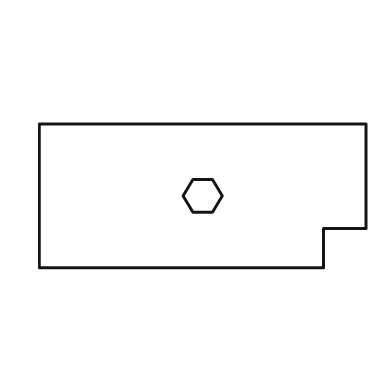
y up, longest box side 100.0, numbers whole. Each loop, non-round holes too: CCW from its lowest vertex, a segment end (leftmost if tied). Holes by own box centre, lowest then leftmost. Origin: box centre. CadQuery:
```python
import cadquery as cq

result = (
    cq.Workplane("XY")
    .moveTo(-50.0, -22.0)
    .lineTo(37.0, -22.0)
    .lineTo(37.0, -10.0)
    .lineTo(50.0, -10.0)
    .lineTo(50.0, 22.0)
    .lineTo(-50.0, 22.0)
    .close()
    .moveTo(-3.0, -5.0)
    .lineTo(3.0, -5.0)
    .lineTo(6.0, 0.0)
    .lineTo(3.0, 5.0)
    .lineTo(-3.0, 5.0)
    .lineTo(-6.0, 0.0)
    .close()
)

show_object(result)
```